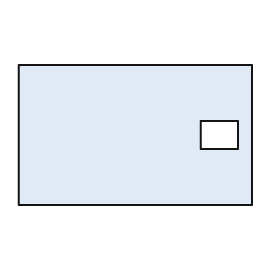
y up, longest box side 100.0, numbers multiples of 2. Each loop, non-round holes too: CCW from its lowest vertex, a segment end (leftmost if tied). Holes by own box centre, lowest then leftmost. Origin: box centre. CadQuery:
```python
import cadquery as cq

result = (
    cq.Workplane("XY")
    .moveTo(-50.0, -30.0)
    .lineTo(50.0, -30.0)
    .lineTo(50.0, 30.0)
    .lineTo(-50.0, 30.0)
    .close()
    .moveTo(28.0, -6.0)
    .lineTo(44.0, -6.0)
    .lineTo(44.0, 6.0)
    .lineTo(28.0, 6.0)
    .close()
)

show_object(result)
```